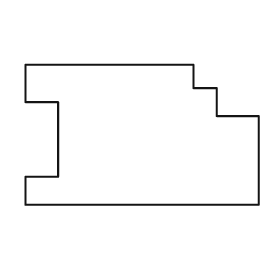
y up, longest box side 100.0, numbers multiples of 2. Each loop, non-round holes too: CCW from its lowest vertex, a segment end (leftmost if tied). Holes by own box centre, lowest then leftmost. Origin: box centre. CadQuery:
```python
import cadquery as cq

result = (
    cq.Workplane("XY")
    .moveTo(-50.0, -30.0)
    .lineTo(50.0, -30.0)
    .lineTo(50.0, 8.0)
    .lineTo(32.0, 8.0)
    .lineTo(32.0, 20.0)
    .lineTo(22.0, 20.0)
    .lineTo(22.0, 30.0)
    .lineTo(-50.0, 30.0)
    .lineTo(-50.0, 14.0)
    .lineTo(-36.0, 14.0)
    .lineTo(-36.0, -18.0)
    .lineTo(-50.0, -18.0)
    .close()
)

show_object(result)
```